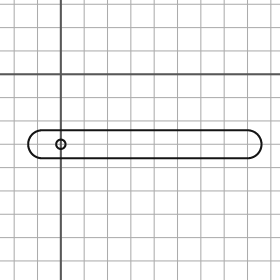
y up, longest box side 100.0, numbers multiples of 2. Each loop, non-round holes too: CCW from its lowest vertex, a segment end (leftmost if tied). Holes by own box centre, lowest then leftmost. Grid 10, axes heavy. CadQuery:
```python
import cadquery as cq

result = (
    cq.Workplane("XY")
    .moveTo(-8.0, -36.0)
    .lineTo(80.0, -36.0)
    .threePointArc((86.0, -30.0), (80.0, -24.0))
    .lineTo(-8.0, -24.0)
    .threePointArc((-14.0, -30.0), (-8.0, -36.0))
    .close()
    .moveTo(0.0, -30.0)
    .circle(2.0)
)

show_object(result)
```